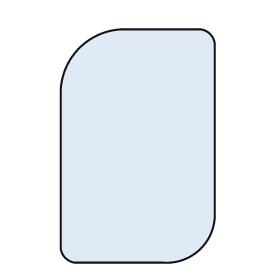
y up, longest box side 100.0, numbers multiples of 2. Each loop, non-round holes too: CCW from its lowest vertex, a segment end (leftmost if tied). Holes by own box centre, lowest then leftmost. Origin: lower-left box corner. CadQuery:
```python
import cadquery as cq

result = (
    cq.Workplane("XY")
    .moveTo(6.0, 0.0)
    .lineTo(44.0, 0.0)
    .threePointArc((60.0, 6.0), (66.0, 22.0))
    .lineTo(66.0, 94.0)
    .threePointArc((64.0, 98.0), (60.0, 100.0))
    .lineTo(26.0, 100.0)
    .threePointArc((8.0, 92.0), (0.0, 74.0))
    .lineTo(0.0, 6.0)
    .threePointArc((2.0, 2.0), (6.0, 0.0))
    .close()
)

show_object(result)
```